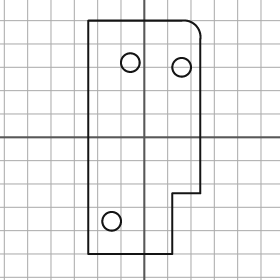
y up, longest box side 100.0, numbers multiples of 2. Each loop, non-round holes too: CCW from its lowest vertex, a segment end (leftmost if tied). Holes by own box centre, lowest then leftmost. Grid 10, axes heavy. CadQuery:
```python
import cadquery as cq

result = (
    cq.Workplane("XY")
    .moveTo(-24.0, -50.0)
    .lineTo(12.0, -50.0)
    .lineTo(12.0, -24.0)
    .lineTo(24.0, -24.0)
    .lineTo(24.0, 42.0)
    .threePointArc((22.0, 48.0), (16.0, 50.0))
    .lineTo(-24.0, 50.0)
    .close()
    .moveTo(-14.0, -36.0)
    .circle(4.0)
    .moveTo(16.0, 30.0)
    .circle(4.0)
    .moveTo(-6.0, 32.0)
    .circle(4.0)
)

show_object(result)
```